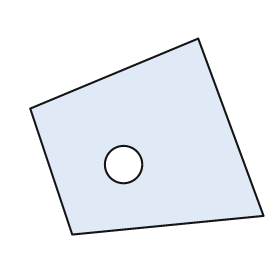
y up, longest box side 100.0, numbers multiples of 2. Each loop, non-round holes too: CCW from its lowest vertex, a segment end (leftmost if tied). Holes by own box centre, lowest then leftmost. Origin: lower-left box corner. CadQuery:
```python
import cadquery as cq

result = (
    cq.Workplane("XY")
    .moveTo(18.0, 0.0)
    .lineTo(100.0, 8.0)
    .lineTo(72.0, 84.0)
    .lineTo(0.0, 54.0)
    .close()
    .moveTo(40.0, 30.0)
    .circle(8.0)
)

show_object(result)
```